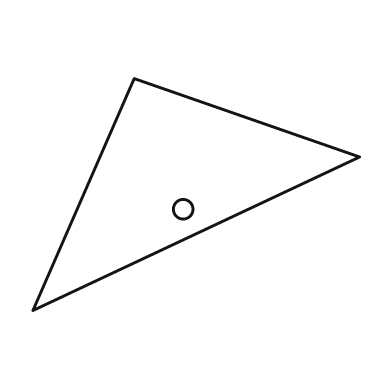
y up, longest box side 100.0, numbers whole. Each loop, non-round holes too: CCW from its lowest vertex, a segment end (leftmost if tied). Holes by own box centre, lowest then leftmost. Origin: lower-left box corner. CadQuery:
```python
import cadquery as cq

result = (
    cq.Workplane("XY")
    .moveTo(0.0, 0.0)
    .lineTo(100.0, 47.0)
    .lineTo(31.0, 71.0)
    .close()
    .moveTo(46.0, 31.0)
    .circle(3.0)
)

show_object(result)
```